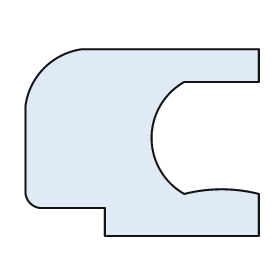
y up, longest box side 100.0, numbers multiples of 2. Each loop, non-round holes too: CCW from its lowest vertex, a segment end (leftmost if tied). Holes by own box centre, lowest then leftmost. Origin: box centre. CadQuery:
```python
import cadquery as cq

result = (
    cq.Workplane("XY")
    .moveTo(-16.0, -40.0)
    .lineTo(50.0, -40.0)
    .lineTo(50.0, -22.0)
    .threePointArc((34.0, -20.0), (18.0, -22.0))
    .threePointArc((4.0, 2.0), (18.0, 26.0))
    .lineTo(50.0, 26.0)
    .lineTo(50.0, 40.0)
    .lineTo(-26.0, 40.0)
    .threePointArc((-42.0, 32.0), (-50.0, 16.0))
    .lineTo(-50.0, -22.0)
    .threePointArc((-48.0, -26.0), (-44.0, -28.0))
    .lineTo(-16.0, -28.0)
    .close()
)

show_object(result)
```